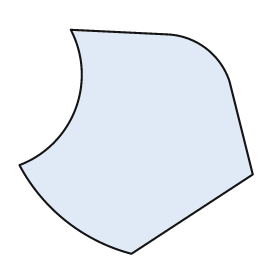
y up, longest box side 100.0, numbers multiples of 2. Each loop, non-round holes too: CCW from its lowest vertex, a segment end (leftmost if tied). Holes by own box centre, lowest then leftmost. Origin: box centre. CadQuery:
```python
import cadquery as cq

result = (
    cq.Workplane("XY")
    .moveTo(-2.0, -48.0)
    .lineTo(50.0, -14.0)
    .lineTo(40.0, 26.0)
    .threePointArc((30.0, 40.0), (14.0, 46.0))
    .lineTo(-28.0, 48.0)
    .threePointArc((-26.0, 14.0), (-50.0, -10.0))
    .threePointArc((-30.0, -34.0), (-2.0, -48.0))
    .close()
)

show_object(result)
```